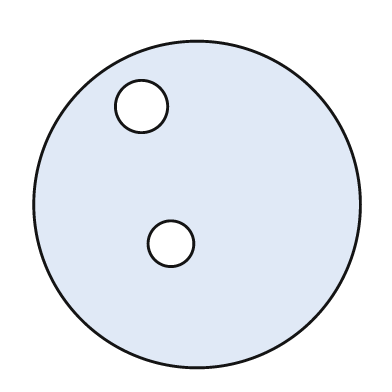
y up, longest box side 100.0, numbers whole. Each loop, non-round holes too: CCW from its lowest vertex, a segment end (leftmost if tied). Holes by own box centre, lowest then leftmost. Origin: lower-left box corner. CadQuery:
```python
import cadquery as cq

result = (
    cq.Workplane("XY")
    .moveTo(50.0, 50.0)
    .circle(50.0)
    .moveTo(42.0, 38.0)
    .circle(7.0)
    .moveTo(33.0, 80.0)
    .circle(8.0)
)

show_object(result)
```